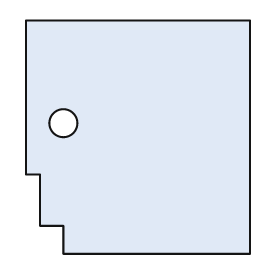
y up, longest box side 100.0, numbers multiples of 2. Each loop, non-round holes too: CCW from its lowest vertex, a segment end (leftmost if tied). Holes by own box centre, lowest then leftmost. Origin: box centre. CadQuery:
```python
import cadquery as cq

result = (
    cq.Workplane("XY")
    .moveTo(-32.0, -50.0)
    .lineTo(48.0, -50.0)
    .lineTo(48.0, 50.0)
    .lineTo(-48.0, 50.0)
    .lineTo(-48.0, -16.0)
    .lineTo(-42.0, -16.0)
    .lineTo(-42.0, -38.0)
    .lineTo(-32.0, -38.0)
    .close()
    .moveTo(-32.0, 6.0)
    .circle(6.0)
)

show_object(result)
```